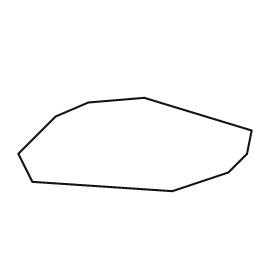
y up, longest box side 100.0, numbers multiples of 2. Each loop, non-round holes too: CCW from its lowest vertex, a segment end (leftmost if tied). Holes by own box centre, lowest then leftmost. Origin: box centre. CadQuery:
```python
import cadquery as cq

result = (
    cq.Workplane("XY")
    .moveTo(16.0, -20.0)
    .lineTo(40.0, -12.0)
    .lineTo(48.0, -4.0)
    .lineTo(50.0, 6.0)
    .lineTo(4.0, 20.0)
    .lineTo(-20.0, 18.0)
    .lineTo(-34.0, 12.0)
    .lineTo(-50.0, -4.0)
    .lineTo(-44.0, -16.0)
    .close()
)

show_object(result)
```